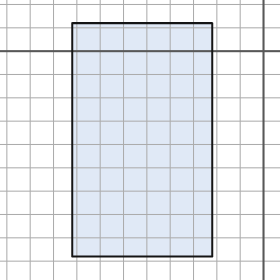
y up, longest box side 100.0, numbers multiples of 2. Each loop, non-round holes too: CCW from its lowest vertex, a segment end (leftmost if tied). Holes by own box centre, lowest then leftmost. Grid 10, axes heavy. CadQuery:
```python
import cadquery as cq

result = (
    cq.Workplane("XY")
    .moveTo(-82.0, -88.0)
    .lineTo(-22.0, -88.0)
    .lineTo(-22.0, 12.0)
    .lineTo(-82.0, 12.0)
    .close()
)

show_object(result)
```